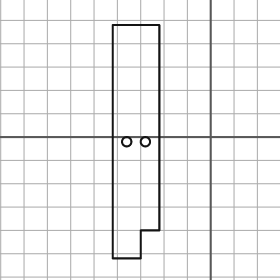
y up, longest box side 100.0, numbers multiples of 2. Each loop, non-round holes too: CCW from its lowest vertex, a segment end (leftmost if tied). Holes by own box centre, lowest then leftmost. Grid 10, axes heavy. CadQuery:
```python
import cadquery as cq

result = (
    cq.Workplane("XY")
    .moveTo(-42.0, -52.0)
    .lineTo(-30.0, -52.0)
    .lineTo(-30.0, -40.0)
    .lineTo(-22.0, -40.0)
    .lineTo(-22.0, 48.0)
    .lineTo(-42.0, 48.0)
    .close()
    .moveTo(-36.0, -2.0)
    .circle(2.0)
    .moveTo(-28.0, -2.0)
    .circle(2.0)
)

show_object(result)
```